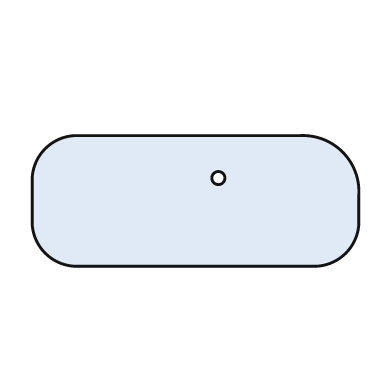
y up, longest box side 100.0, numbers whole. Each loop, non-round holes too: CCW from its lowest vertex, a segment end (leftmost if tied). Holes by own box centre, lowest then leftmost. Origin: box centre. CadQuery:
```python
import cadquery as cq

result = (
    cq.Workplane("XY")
    .moveTo(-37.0, -20.0)
    .lineTo(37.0, -20.0)
    .threePointArc((46.0, -16.0), (50.0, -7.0))
    .lineTo(50.0, 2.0)
    .threePointArc((45.0, 15.0), (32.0, 20.0))
    .lineTo(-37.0, 20.0)
    .threePointArc((-46.0, 16.0), (-50.0, 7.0))
    .lineTo(-50.0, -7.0)
    .threePointArc((-46.0, -16.0), (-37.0, -20.0))
    .close()
    .moveTo(7.0, 7.0)
    .circle(2.0)
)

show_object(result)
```